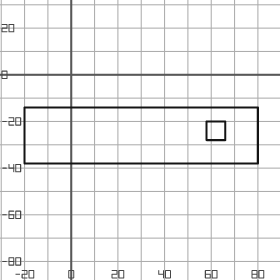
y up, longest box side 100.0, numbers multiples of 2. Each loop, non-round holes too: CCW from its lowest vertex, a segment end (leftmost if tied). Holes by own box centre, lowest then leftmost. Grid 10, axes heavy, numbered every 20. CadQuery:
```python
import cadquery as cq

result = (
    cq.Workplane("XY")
    .moveTo(-20.0, -38.0)
    .lineTo(80.0, -38.0)
    .lineTo(80.0, -14.0)
    .lineTo(-20.0, -14.0)
    .close()
    .moveTo(58.0, -28.0)
    .lineTo(66.0, -28.0)
    .lineTo(66.0, -20.0)
    .lineTo(58.0, -20.0)
    .close()
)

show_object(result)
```